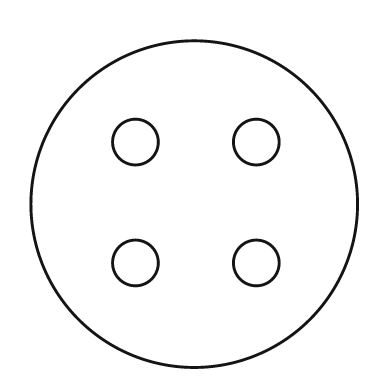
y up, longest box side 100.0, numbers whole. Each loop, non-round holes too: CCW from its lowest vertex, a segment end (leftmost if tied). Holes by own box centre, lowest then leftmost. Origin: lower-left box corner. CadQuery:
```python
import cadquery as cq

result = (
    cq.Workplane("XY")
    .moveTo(50.0, 50.0)
    .circle(50.0)
    .moveTo(32.0, 32.0)
    .circle(7.0)
    .moveTo(69.0, 32.0)
    .circle(7.0)
    .moveTo(32.0, 69.0)
    .circle(7.0)
    .moveTo(69.0, 69.0)
    .circle(7.0)
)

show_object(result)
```